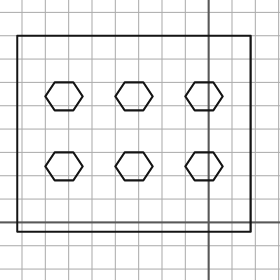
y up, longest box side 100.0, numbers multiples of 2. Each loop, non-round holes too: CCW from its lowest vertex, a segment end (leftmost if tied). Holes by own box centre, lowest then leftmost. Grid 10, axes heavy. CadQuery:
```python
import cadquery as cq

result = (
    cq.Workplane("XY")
    .moveTo(-82.0, -4.0)
    .lineTo(18.0, -4.0)
    .lineTo(18.0, 80.0)
    .lineTo(-82.0, 80.0)
    .close()
    .moveTo(-66.0, 18.0)
    .lineTo(-58.0, 18.0)
    .lineTo(-54.0, 24.0)
    .lineTo(-58.0, 30.0)
    .lineTo(-66.0, 30.0)
    .lineTo(-70.0, 24.0)
    .close()
    .moveTo(-36.0, 18.0)
    .lineTo(-28.0, 18.0)
    .lineTo(-24.0, 24.0)
    .lineTo(-28.0, 30.0)
    .lineTo(-36.0, 30.0)
    .lineTo(-40.0, 24.0)
    .close()
    .moveTo(-6.0, 18.0)
    .lineTo(2.0, 18.0)
    .lineTo(6.0, 24.0)
    .lineTo(2.0, 30.0)
    .lineTo(-6.0, 30.0)
    .lineTo(-10.0, 24.0)
    .close()
    .moveTo(-66.0, 48.0)
    .lineTo(-58.0, 48.0)
    .lineTo(-54.0, 54.0)
    .lineTo(-58.0, 60.0)
    .lineTo(-66.0, 60.0)
    .lineTo(-70.0, 54.0)
    .close()
    .moveTo(-36.0, 48.0)
    .lineTo(-28.0, 48.0)
    .lineTo(-24.0, 54.0)
    .lineTo(-28.0, 60.0)
    .lineTo(-36.0, 60.0)
    .lineTo(-40.0, 54.0)
    .close()
    .moveTo(-6.0, 48.0)
    .lineTo(2.0, 48.0)
    .lineTo(6.0, 54.0)
    .lineTo(2.0, 60.0)
    .lineTo(-6.0, 60.0)
    .lineTo(-10.0, 54.0)
    .close()
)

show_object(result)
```